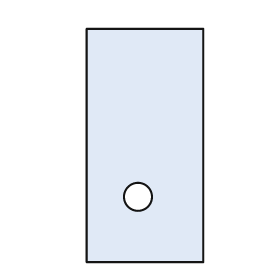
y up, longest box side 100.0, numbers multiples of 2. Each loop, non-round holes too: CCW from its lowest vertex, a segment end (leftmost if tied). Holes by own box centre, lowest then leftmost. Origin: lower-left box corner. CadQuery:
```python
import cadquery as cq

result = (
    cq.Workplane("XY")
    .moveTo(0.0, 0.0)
    .lineTo(50.0, 0.0)
    .lineTo(50.0, 100.0)
    .lineTo(0.0, 100.0)
    .close()
    .moveTo(22.0, 28.0)
    .circle(6.0)
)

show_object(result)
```